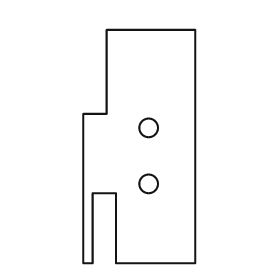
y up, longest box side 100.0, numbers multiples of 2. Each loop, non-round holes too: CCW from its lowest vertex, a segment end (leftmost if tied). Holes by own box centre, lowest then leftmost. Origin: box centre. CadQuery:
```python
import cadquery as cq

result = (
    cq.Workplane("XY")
    .moveTo(-24.0, -50.0)
    .lineTo(-20.0, -50.0)
    .lineTo(-20.0, -20.0)
    .lineTo(-10.0, -20.0)
    .lineTo(-10.0, -50.0)
    .lineTo(24.0, -50.0)
    .lineTo(24.0, 50.0)
    .lineTo(-14.0, 50.0)
    .lineTo(-14.0, 14.0)
    .lineTo(-24.0, 14.0)
    .close()
    .moveTo(4.0, -16.0)
    .circle(4.0)
    .moveTo(4.0, 8.0)
    .circle(4.0)
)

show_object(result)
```